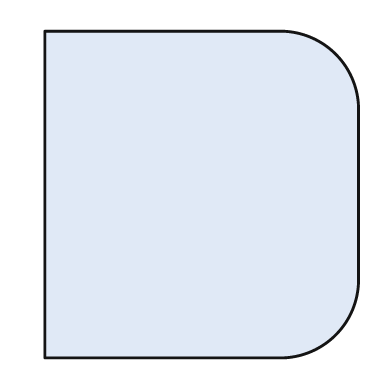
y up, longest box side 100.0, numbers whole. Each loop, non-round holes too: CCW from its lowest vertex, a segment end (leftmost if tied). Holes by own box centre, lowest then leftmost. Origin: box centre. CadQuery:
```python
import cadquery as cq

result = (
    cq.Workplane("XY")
    .moveTo(-48.0, -50.0)
    .lineTo(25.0, -50.0)
    .threePointArc((41.0, -43.0), (48.0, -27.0))
    .lineTo(48.0, 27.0)
    .threePointArc((41.0, 43.0), (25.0, 50.0))
    .lineTo(-48.0, 50.0)
    .close()
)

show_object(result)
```